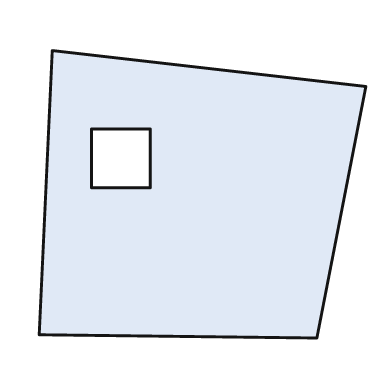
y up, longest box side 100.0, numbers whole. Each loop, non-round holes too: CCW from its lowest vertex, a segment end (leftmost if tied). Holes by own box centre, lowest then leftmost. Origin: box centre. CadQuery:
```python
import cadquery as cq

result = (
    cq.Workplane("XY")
    .moveTo(35.0, -44.0)
    .lineTo(50.0, 33.0)
    .lineTo(-46.0, 44.0)
    .lineTo(-50.0, -43.0)
    .close()
    .moveTo(-34.0, 2.0)
    .lineTo(-16.0, 2.0)
    .lineTo(-16.0, 20.0)
    .lineTo(-34.0, 20.0)
    .close()
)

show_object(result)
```